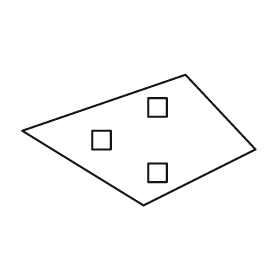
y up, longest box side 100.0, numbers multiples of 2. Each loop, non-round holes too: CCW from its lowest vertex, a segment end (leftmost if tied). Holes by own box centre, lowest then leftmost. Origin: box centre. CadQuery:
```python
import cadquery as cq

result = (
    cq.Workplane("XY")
    .moveTo(2.0, -28.0)
    .lineTo(50.0, -4.0)
    .lineTo(20.0, 28.0)
    .lineTo(-50.0, 4.0)
    .close()
    .moveTo(4.0, -18.0)
    .lineTo(12.0, -18.0)
    .lineTo(12.0, -10.0)
    .lineTo(4.0, -10.0)
    .close()
    .moveTo(-20.0, -4.0)
    .lineTo(-12.0, -4.0)
    .lineTo(-12.0, 4.0)
    .lineTo(-20.0, 4.0)
    .close()
    .moveTo(4.0, 10.0)
    .lineTo(12.0, 10.0)
    .lineTo(12.0, 18.0)
    .lineTo(4.0, 18.0)
    .close()
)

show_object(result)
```